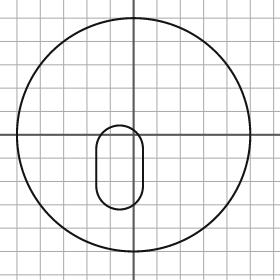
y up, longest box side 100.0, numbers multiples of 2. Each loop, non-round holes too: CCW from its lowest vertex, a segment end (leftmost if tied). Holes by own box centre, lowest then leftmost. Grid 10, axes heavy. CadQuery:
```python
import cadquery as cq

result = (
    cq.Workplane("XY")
    .moveTo(0.0, 0.0)
    .circle(50.0)
    .moveTo(-16.0, -22.0)
    .threePointArc((-6.0, -32.0), (4.0, -22.0))
    .lineTo(4.0, -6.0)
    .threePointArc((-6.0, 4.0), (-16.0, -6.0))
    .close()
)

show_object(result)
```